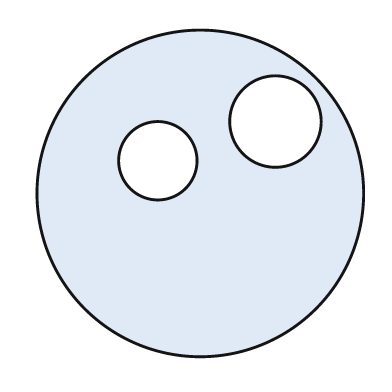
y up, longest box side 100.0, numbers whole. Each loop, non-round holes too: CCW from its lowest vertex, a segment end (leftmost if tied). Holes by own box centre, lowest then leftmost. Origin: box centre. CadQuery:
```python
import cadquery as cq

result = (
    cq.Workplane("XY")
    .moveTo(0.0, 0.0)
    .circle(50.0)
    .moveTo(-13.0, 10.0)
    .circle(12.0)
    .moveTo(23.0, 22.0)
    .circle(14.0)
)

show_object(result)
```